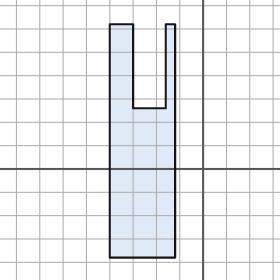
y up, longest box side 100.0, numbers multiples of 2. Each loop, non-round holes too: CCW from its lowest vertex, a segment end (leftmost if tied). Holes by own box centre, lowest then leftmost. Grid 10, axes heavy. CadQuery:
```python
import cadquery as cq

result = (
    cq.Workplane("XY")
    .moveTo(-40.0, -38.0)
    .lineTo(-12.0, -38.0)
    .lineTo(-12.0, 62.0)
    .lineTo(-16.0, 62.0)
    .lineTo(-16.0, 26.0)
    .lineTo(-30.0, 26.0)
    .lineTo(-30.0, 62.0)
    .lineTo(-40.0, 62.0)
    .close()
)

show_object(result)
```